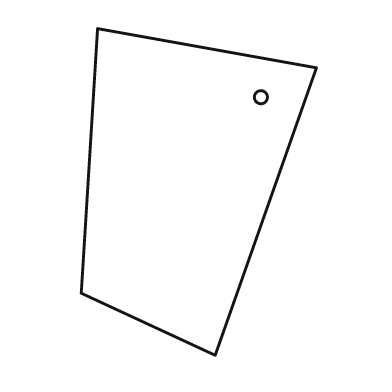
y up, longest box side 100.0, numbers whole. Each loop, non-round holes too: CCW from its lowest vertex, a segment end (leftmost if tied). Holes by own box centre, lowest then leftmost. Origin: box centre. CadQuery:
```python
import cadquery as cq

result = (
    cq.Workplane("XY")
    .moveTo(5.0, -50.0)
    .lineTo(36.0, 38.0)
    .lineTo(-31.0, 50.0)
    .lineTo(-36.0, -31.0)
    .close()
    .moveTo(19.0, 29.0)
    .circle(2.0)
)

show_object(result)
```